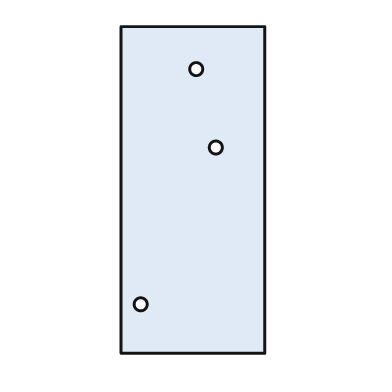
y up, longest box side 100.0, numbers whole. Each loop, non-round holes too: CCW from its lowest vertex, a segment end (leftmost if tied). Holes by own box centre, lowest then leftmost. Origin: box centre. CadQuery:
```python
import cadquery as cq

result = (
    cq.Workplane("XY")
    .moveTo(-22.0, -50.0)
    .lineTo(22.0, -50.0)
    .lineTo(22.0, 50.0)
    .lineTo(-22.0, 50.0)
    .close()
    .moveTo(-16.0, -35.0)
    .circle(2.0)
    .moveTo(7.0, 13.0)
    .circle(2.0)
    .moveTo(1.0, 37.0)
    .circle(2.0)
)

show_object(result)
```